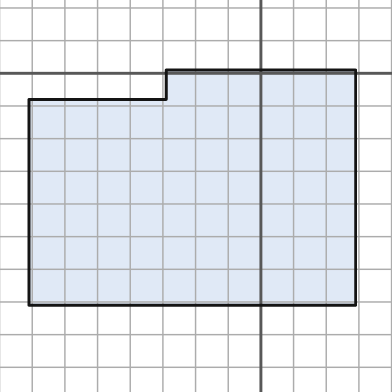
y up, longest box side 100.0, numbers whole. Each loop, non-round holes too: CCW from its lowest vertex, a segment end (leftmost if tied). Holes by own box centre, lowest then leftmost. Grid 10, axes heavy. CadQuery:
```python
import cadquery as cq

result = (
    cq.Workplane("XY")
    .moveTo(-71.0, -71.0)
    .lineTo(29.0, -71.0)
    .lineTo(29.0, 1.0)
    .lineTo(-29.0, 1.0)
    .lineTo(-29.0, -8.0)
    .lineTo(-71.0, -8.0)
    .close()
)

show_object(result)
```